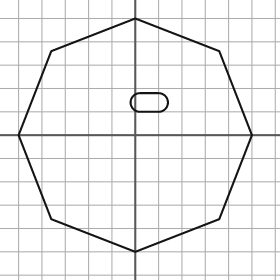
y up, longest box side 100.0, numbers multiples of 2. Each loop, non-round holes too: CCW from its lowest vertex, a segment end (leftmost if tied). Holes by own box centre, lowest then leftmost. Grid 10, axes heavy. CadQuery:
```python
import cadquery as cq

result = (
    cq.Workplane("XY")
    .moveTo(0.0, -50.0)
    .lineTo(36.0, -36.0)
    .lineTo(50.0, 0.0)
    .lineTo(36.0, 36.0)
    .lineTo(0.0, 50.0)
    .lineTo(-36.0, 36.0)
    .lineTo(-50.0, 0.0)
    .lineTo(-36.0, -36.0)
    .close()
    .moveTo(2.0, 10.0)
    .lineTo(10.0, 10.0)
    .threePointArc((14.0, 14.0), (10.0, 18.0))
    .lineTo(2.0, 18.0)
    .threePointArc((-2.0, 14.0), (2.0, 10.0))
    .close()
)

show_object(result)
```